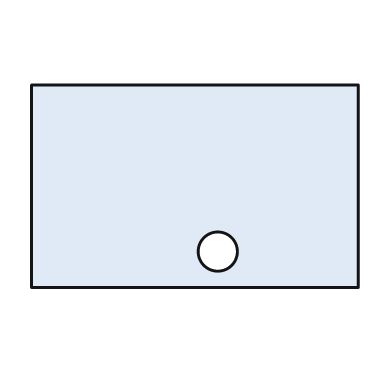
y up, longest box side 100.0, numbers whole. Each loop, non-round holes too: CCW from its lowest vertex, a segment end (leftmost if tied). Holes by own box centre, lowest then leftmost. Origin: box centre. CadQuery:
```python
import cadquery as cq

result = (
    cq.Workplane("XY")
    .moveTo(-50.0, -31.0)
    .lineTo(50.0, -31.0)
    .lineTo(50.0, 31.0)
    .lineTo(-50.0, 31.0)
    .close()
    .moveTo(7.0, -20.0)
    .circle(6.0)
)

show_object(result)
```